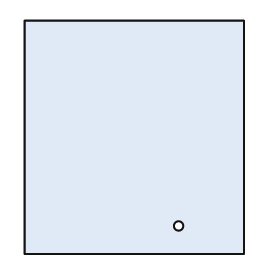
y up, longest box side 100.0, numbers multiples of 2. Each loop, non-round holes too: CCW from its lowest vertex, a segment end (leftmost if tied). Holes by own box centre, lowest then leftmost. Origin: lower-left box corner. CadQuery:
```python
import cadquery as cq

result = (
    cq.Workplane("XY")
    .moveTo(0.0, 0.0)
    .lineTo(94.0, 0.0)
    .lineTo(94.0, 100.0)
    .lineTo(0.0, 100.0)
    .close()
    .moveTo(66.0, 12.0)
    .circle(2.0)
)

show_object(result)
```